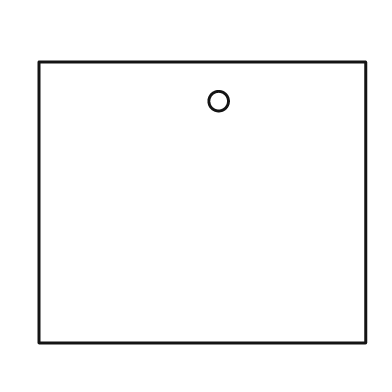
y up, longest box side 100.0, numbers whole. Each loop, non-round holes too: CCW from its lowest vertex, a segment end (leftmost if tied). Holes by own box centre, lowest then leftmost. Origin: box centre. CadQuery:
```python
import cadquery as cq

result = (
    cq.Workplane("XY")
    .moveTo(-50.0, -43.0)
    .lineTo(50.0, -43.0)
    .lineTo(50.0, 43.0)
    .lineTo(-50.0, 43.0)
    .close()
    .moveTo(5.0, 31.0)
    .circle(3.0)
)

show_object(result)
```